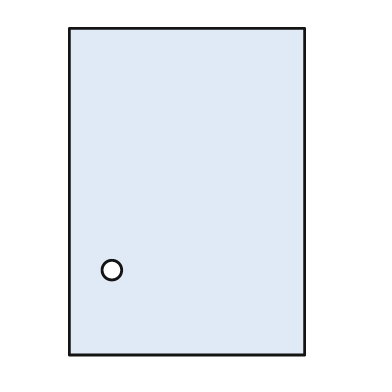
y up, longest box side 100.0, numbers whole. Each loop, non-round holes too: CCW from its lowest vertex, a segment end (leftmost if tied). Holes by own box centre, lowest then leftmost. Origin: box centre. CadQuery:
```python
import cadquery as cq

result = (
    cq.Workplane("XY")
    .moveTo(-36.0, -50.0)
    .lineTo(36.0, -50.0)
    .lineTo(36.0, 50.0)
    .lineTo(-36.0, 50.0)
    .close()
    .moveTo(-23.0, -24.0)
    .circle(3.0)
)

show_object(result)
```